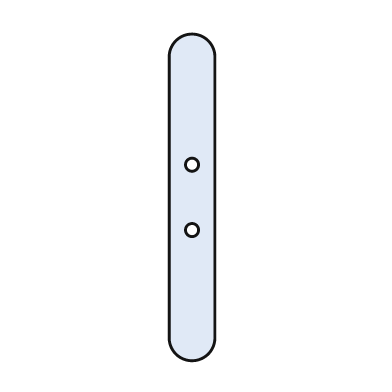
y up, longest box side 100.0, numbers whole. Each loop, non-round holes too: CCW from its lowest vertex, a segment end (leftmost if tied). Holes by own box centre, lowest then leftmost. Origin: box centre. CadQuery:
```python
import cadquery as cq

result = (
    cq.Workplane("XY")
    .moveTo(-7.0, -43.0)
    .threePointArc((0.0, -50.0), (7.0, -43.0))
    .lineTo(7.0, 43.0)
    .threePointArc((0.0, 50.0), (-7.0, 43.0))
    .close()
    .moveTo(0.0, -10.0)
    .circle(2.0)
    .moveTo(0.0, 10.0)
    .circle(2.0)
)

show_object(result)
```